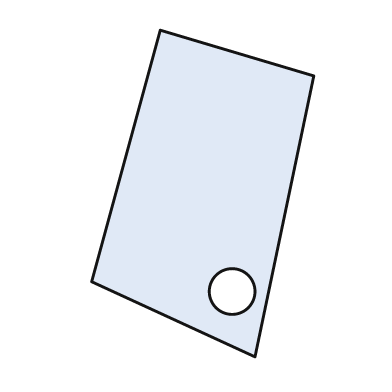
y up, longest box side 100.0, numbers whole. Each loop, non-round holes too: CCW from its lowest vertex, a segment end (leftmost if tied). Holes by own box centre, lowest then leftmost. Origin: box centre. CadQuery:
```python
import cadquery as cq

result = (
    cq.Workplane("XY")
    .moveTo(16.0, -50.0)
    .lineTo(34.0, 36.0)
    .lineTo(-13.0, 50.0)
    .lineTo(-34.0, -27.0)
    .close()
    .moveTo(9.0, -30.0)
    .circle(7.0)
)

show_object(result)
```